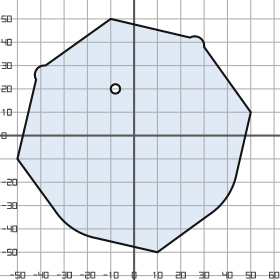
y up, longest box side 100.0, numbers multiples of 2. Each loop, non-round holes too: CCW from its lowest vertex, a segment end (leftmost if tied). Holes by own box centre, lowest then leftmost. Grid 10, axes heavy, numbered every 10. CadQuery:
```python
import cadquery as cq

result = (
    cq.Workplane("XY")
    .moveTo(10.0, -50.0)
    .lineTo(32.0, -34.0)
    .threePointArc((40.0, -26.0), (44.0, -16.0))
    .lineTo(50.0, 10.0)
    .lineTo(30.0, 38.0)
    .threePointArc((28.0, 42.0), (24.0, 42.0))
    .lineTo(-10.0, 50.0)
    .lineTo(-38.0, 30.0)
    .threePointArc((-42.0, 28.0), (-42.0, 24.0))
    .lineTo(-50.0, -10.0)
    .lineTo(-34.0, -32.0)
    .threePointArc((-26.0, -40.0), (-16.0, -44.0))
    .close()
    .moveTo(-8.0, 20.0)
    .circle(2.0)
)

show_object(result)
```